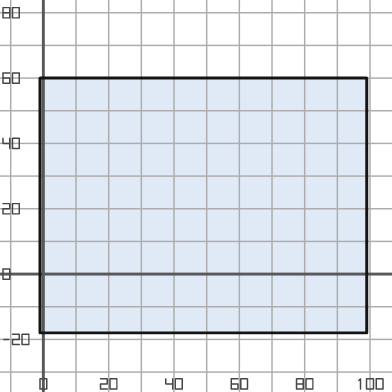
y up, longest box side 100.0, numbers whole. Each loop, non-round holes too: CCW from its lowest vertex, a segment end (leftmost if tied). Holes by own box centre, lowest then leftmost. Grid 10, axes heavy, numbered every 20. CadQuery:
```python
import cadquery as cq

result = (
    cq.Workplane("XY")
    .moveTo(-1.0, -18.0)
    .lineTo(99.0, -18.0)
    .lineTo(99.0, 60.0)
    .lineTo(-1.0, 60.0)
    .close()
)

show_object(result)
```